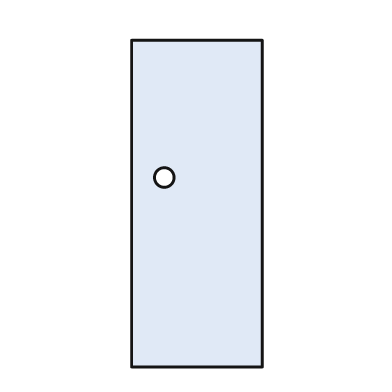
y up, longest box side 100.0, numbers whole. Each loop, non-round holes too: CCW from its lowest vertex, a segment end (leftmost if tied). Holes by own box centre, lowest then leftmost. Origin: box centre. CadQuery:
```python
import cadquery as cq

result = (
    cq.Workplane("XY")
    .moveTo(-20.0, -50.0)
    .lineTo(20.0, -50.0)
    .lineTo(20.0, 50.0)
    .lineTo(-20.0, 50.0)
    .close()
    .moveTo(-10.0, 8.0)
    .circle(3.0)
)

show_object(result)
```